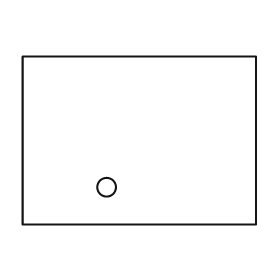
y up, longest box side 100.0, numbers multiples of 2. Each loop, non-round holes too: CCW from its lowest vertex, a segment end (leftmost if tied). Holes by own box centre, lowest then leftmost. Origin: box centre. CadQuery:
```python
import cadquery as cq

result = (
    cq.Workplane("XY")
    .moveTo(-50.0, -36.0)
    .lineTo(50.0, -36.0)
    .lineTo(50.0, 36.0)
    .lineTo(-50.0, 36.0)
    .close()
    .moveTo(-14.0, -20.0)
    .circle(4.0)
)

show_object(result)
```